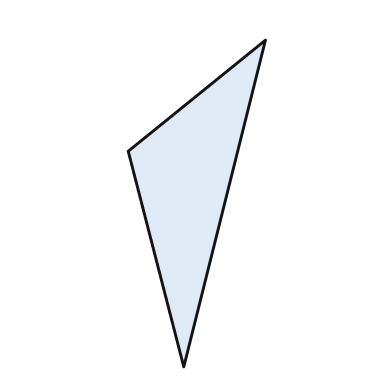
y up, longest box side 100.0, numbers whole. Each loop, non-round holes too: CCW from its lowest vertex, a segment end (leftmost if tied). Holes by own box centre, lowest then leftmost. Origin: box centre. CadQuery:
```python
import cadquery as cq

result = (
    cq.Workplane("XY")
    .moveTo(-4.0, -50.0)
    .lineTo(21.0, 50.0)
    .lineTo(-21.0, 16.0)
    .close()
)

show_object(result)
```